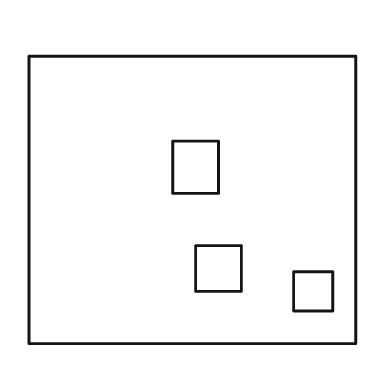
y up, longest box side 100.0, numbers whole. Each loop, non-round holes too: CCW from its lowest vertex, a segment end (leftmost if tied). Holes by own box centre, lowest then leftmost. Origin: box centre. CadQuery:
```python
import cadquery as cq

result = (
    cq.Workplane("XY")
    .moveTo(-50.0, -44.0)
    .lineTo(50.0, -44.0)
    .lineTo(50.0, 44.0)
    .lineTo(-50.0, 44.0)
    .close()
    .moveTo(31.0, -34.0)
    .lineTo(43.0, -34.0)
    .lineTo(43.0, -22.0)
    .lineTo(31.0, -22.0)
    .close()
    .moveTo(1.0, -28.0)
    .lineTo(15.0, -28.0)
    .lineTo(15.0, -14.0)
    .lineTo(1.0, -14.0)
    .close()
    .moveTo(-6.0, 2.0)
    .lineTo(8.0, 2.0)
    .lineTo(8.0, 18.0)
    .lineTo(-6.0, 18.0)
    .close()
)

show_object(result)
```